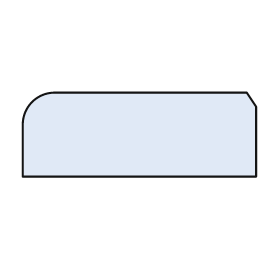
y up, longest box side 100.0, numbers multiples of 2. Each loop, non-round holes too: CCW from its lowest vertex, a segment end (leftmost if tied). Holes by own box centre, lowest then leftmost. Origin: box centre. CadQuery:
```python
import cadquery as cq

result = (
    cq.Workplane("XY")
    .moveTo(-50.0, -18.0)
    .lineTo(50.0, -18.0)
    .lineTo(50.0, 12.0)
    .lineTo(46.0, 18.0)
    .lineTo(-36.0, 18.0)
    .threePointArc((-46.0, 14.0), (-50.0, 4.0))
    .close()
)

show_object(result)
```